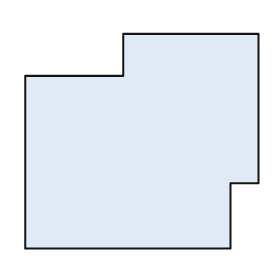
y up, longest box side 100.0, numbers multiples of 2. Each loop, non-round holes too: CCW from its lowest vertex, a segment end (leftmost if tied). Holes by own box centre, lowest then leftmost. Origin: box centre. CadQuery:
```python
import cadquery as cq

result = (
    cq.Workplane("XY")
    .moveTo(-50.0, -46.0)
    .lineTo(38.0, -46.0)
    .lineTo(38.0, -18.0)
    .lineTo(50.0, -18.0)
    .lineTo(50.0, 46.0)
    .lineTo(-8.0, 46.0)
    .lineTo(-8.0, 28.0)
    .lineTo(-50.0, 28.0)
    .close()
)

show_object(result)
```